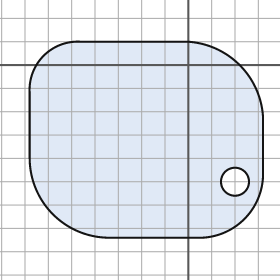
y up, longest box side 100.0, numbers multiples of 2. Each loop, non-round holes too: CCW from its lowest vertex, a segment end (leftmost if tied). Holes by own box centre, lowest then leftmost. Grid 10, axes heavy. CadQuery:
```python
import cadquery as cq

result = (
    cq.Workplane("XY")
    .moveTo(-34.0, -74.0)
    .lineTo(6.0, -74.0)
    .threePointArc((24.0, -66.0), (32.0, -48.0))
    .lineTo(32.0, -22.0)
    .threePointArc((22.0, 0.0), (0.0, 10.0))
    .lineTo(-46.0, 10.0)
    .threePointArc((-62.0, 4.0), (-68.0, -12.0))
    .lineTo(-68.0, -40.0)
    .threePointArc((-58.0, -64.0), (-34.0, -74.0))
    .close()
    .moveTo(20.0, -50.0)
    .circle(6.0)
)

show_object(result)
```